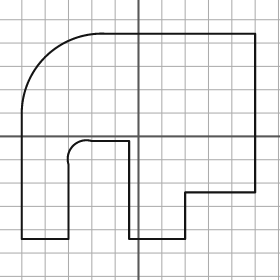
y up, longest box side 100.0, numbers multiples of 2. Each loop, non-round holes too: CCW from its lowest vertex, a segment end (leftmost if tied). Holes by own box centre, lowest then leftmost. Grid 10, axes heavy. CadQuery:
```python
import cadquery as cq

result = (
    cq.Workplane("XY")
    .moveTo(-50.0, -44.0)
    .lineTo(-30.0, -44.0)
    .lineTo(-30.0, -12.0)
    .threePointArc((-28.0, -4.0), (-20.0, -2.0))
    .lineTo(-4.0, -2.0)
    .lineTo(-4.0, -44.0)
    .lineTo(20.0, -44.0)
    .lineTo(20.0, -24.0)
    .lineTo(50.0, -24.0)
    .lineTo(50.0, 44.0)
    .lineTo(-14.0, 44.0)
    .threePointArc((-40.0, 34.0), (-50.0, 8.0))
    .close()
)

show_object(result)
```